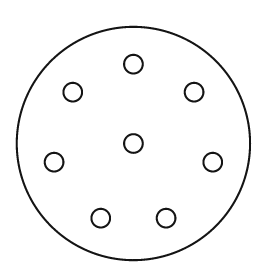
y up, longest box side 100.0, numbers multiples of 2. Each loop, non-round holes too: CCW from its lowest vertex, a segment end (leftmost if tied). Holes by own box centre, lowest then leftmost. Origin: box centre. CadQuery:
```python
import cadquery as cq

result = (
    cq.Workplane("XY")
    .moveTo(0.0, 0.0)
    .circle(50.0)
    .moveTo(-14.0, -32.0)
    .circle(4.0)
    .moveTo(14.0, -32.0)
    .circle(4.0)
    .moveTo(-34.0, -8.0)
    .circle(4.0)
    .moveTo(34.0, -8.0)
    .circle(4.0)
    .moveTo(0.0, 0.0)
    .circle(4.0)
    .moveTo(-26.0, 22.0)
    .circle(4.0)
    .moveTo(26.0, 22.0)
    .circle(4.0)
    .moveTo(0.0, 34.0)
    .circle(4.0)
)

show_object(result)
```